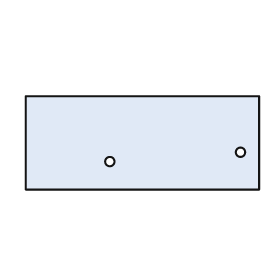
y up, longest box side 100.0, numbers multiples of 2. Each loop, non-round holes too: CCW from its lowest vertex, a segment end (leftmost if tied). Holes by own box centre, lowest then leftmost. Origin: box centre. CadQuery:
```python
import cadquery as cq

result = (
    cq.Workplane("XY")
    .moveTo(-50.0, -20.0)
    .lineTo(50.0, -20.0)
    .lineTo(50.0, 20.0)
    .lineTo(-50.0, 20.0)
    .close()
    .moveTo(-14.0, -8.0)
    .circle(2.0)
    .moveTo(42.0, -4.0)
    .circle(2.0)
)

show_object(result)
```